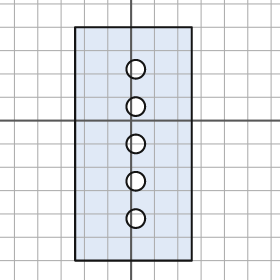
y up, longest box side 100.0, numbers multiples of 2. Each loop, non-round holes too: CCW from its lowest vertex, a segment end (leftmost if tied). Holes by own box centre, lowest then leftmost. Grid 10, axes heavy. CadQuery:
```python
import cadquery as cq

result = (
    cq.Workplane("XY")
    .moveTo(-24.0, -60.0)
    .lineTo(26.0, -60.0)
    .lineTo(26.0, 40.0)
    .lineTo(-24.0, 40.0)
    .close()
    .moveTo(2.0, -42.0)
    .circle(4.0)
    .moveTo(2.0, -26.0)
    .circle(4.0)
    .moveTo(2.0, -10.0)
    .circle(4.0)
    .moveTo(2.0, 6.0)
    .circle(4.0)
    .moveTo(2.0, 22.0)
    .circle(4.0)
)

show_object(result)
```